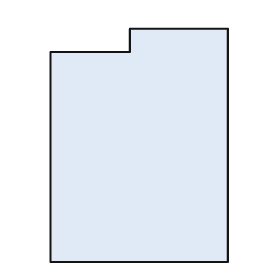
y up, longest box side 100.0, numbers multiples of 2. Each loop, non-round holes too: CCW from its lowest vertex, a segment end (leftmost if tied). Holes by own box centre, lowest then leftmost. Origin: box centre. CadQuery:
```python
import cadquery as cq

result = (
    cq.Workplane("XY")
    .moveTo(-38.0, -50.0)
    .lineTo(38.0, -50.0)
    .lineTo(38.0, 50.0)
    .lineTo(-4.0, 50.0)
    .lineTo(-4.0, 40.0)
    .lineTo(-38.0, 40.0)
    .close()
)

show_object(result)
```